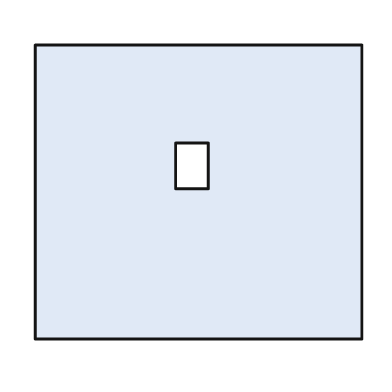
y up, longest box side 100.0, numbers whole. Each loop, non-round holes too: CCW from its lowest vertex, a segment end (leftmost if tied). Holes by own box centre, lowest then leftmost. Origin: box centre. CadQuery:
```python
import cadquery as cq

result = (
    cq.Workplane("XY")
    .moveTo(-50.0, -45.0)
    .lineTo(50.0, -45.0)
    .lineTo(50.0, 45.0)
    .lineTo(-50.0, 45.0)
    .close()
    .moveTo(-7.0, 1.0)
    .lineTo(3.0, 1.0)
    .lineTo(3.0, 15.0)
    .lineTo(-7.0, 15.0)
    .close()
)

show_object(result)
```